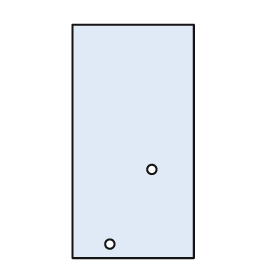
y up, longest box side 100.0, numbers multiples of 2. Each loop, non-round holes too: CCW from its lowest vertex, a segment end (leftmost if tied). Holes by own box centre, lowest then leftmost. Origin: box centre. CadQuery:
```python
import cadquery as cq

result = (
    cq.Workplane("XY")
    .moveTo(-26.0, -50.0)
    .lineTo(26.0, -50.0)
    .lineTo(26.0, 50.0)
    .lineTo(-26.0, 50.0)
    .close()
    .moveTo(-10.0, -44.0)
    .circle(2.0)
    .moveTo(8.0, -12.0)
    .circle(2.0)
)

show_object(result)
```